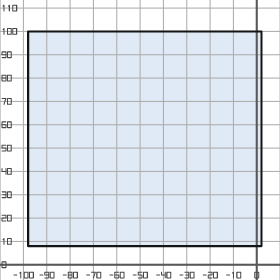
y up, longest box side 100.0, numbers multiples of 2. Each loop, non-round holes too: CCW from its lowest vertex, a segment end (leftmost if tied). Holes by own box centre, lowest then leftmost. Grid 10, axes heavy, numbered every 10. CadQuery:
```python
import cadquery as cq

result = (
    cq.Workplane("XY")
    .moveTo(-98.0, 8.0)
    .lineTo(2.0, 8.0)
    .lineTo(2.0, 100.0)
    .lineTo(-98.0, 100.0)
    .close()
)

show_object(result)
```